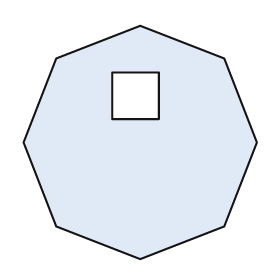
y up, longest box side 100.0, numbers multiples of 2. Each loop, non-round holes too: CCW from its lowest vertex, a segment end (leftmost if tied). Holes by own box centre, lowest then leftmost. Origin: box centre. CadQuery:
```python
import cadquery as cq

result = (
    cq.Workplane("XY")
    .moveTo(0.0, -50.0)
    .lineTo(36.0, -36.0)
    .lineTo(50.0, 0.0)
    .lineTo(36.0, 36.0)
    .lineTo(0.0, 50.0)
    .lineTo(-36.0, 36.0)
    .lineTo(-50.0, 0.0)
    .lineTo(-36.0, -36.0)
    .close()
    .moveTo(-12.0, 10.0)
    .lineTo(8.0, 10.0)
    .lineTo(8.0, 30.0)
    .lineTo(-12.0, 30.0)
    .close()
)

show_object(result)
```